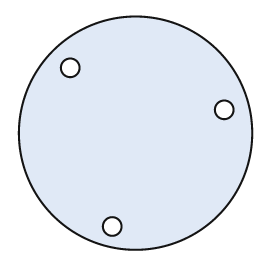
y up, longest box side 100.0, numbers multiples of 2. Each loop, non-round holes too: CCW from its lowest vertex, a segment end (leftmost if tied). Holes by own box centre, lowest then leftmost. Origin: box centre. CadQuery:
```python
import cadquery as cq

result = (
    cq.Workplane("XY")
    .moveTo(0.0, 0.0)
    .circle(50.0)
    .moveTo(-10.0, -40.0)
    .circle(4.0)
    .moveTo(38.0, 10.0)
    .circle(4.0)
    .moveTo(-28.0, 28.0)
    .circle(4.0)
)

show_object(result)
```